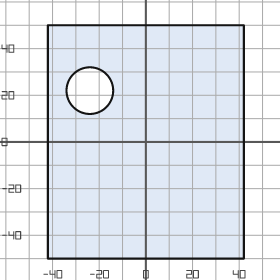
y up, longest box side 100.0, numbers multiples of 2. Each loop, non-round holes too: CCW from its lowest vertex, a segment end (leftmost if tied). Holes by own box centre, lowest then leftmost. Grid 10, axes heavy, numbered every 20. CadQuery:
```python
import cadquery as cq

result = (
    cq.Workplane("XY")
    .moveTo(-42.0, -50.0)
    .lineTo(42.0, -50.0)
    .lineTo(42.0, 50.0)
    .lineTo(-42.0, 50.0)
    .close()
    .moveTo(-24.0, 22.0)
    .circle(10.0)
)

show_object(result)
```